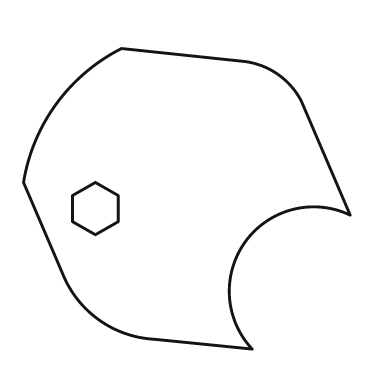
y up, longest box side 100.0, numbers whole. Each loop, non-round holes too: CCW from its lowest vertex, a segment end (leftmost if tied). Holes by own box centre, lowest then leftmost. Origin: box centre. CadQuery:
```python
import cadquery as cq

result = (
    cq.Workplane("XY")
    .moveTo(20.0, -46.0)
    .threePointArc((18.0, -13.0), (50.0, -5.0))
    .lineTo(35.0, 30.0)
    .threePointArc((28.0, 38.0), (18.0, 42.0))
    .lineTo(-20.0, 46.0)
    .threePointArc((-40.0, 29.0), (-50.0, 5.0))
    .lineTo(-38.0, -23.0)
    .threePointArc((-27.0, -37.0), (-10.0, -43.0))
    .close()
    .moveTo(-28.0, -11.0)
    .lineTo(-21.0, -7.0)
    .lineTo(-21.0, 1.0)
    .lineTo(-28.0, 5.0)
    .lineTo(-35.0, 1.0)
    .lineTo(-35.0, -7.0)
    .close()
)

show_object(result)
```